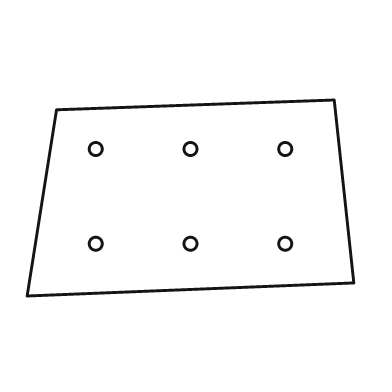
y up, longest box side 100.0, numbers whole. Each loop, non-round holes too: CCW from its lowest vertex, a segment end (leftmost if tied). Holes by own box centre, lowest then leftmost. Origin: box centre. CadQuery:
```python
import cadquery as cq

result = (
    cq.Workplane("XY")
    .moveTo(-50.0, -30.0)
    .lineTo(50.0, -26.0)
    .lineTo(44.0, 30.0)
    .lineTo(-41.0, 27.0)
    .close()
    .moveTo(-29.0, -14.0)
    .circle(2.0)
    .moveTo(0.0, -14.0)
    .circle(2.0)
    .moveTo(29.0, -14.0)
    .circle(2.0)
    .moveTo(-29.0, 15.0)
    .circle(2.0)
    .moveTo(0.0, 15.0)
    .circle(2.0)
    .moveTo(29.0, 15.0)
    .circle(2.0)
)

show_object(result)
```